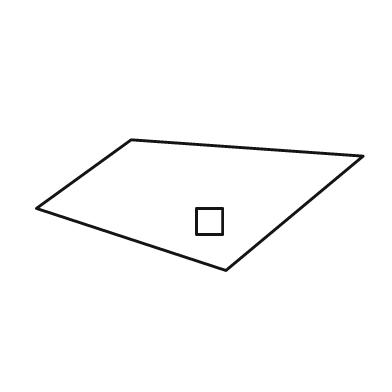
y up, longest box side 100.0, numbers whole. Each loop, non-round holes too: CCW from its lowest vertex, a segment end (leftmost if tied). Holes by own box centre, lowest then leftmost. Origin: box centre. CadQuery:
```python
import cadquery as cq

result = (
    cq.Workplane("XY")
    .moveTo(8.0, -20.0)
    .lineTo(50.0, 15.0)
    .lineTo(-21.0, 20.0)
    .lineTo(-50.0, -1.0)
    .close()
    .moveTo(-1.0, -9.0)
    .lineTo(7.0, -9.0)
    .lineTo(7.0, -1.0)
    .lineTo(-1.0, -1.0)
    .close()
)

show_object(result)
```